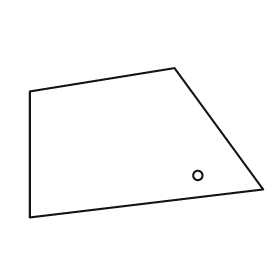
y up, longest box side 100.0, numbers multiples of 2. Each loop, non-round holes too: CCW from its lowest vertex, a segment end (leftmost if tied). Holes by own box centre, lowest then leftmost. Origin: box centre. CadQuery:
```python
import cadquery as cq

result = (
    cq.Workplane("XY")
    .moveTo(-50.0, -32.0)
    .lineTo(50.0, -20.0)
    .lineTo(12.0, 32.0)
    .lineTo(-50.0, 22.0)
    .close()
    .moveTo(22.0, -14.0)
    .circle(2.0)
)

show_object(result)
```